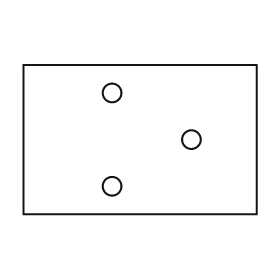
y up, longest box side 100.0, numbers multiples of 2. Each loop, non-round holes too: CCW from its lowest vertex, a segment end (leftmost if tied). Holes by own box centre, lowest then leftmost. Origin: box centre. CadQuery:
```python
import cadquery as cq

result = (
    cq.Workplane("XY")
    .moveTo(-50.0, -32.0)
    .lineTo(50.0, -32.0)
    .lineTo(50.0, 32.0)
    .lineTo(-50.0, 32.0)
    .close()
    .moveTo(-12.0, -20.0)
    .circle(4.0)
    .moveTo(22.0, 0.0)
    .circle(4.0)
    .moveTo(-12.0, 20.0)
    .circle(4.0)
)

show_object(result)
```